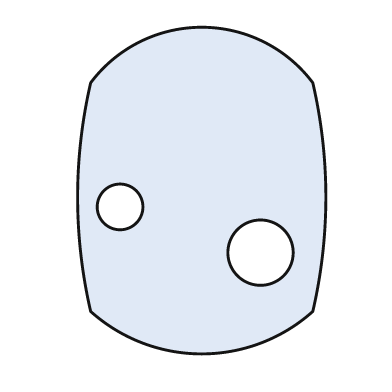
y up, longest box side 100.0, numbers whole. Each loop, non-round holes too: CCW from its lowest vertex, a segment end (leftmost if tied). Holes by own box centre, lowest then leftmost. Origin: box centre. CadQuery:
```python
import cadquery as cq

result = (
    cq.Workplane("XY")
    .moveTo(-34.0, -37.0)
    .threePointArc((0.0, -50.0), (34.0, -37.0))
    .threePointArc((38.0, -2.0), (34.0, 33.0))
    .threePointArc((0.0, 50.0), (-34.0, 33.0))
    .threePointArc((-38.0, -2.0), (-34.0, -37.0))
    .close()
    .moveTo(18.0, -19.0)
    .circle(10.0)
    .moveTo(-25.0, -5.0)
    .circle(7.0)
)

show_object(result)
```